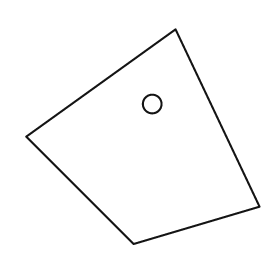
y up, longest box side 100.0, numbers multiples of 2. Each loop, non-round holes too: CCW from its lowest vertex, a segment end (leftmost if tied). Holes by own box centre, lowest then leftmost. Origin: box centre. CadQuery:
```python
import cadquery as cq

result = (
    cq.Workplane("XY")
    .moveTo(-4.0, -46.0)
    .lineTo(50.0, -30.0)
    .lineTo(14.0, 46.0)
    .lineTo(-50.0, 0.0)
    .close()
    .moveTo(4.0, 14.0)
    .circle(4.0)
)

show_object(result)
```